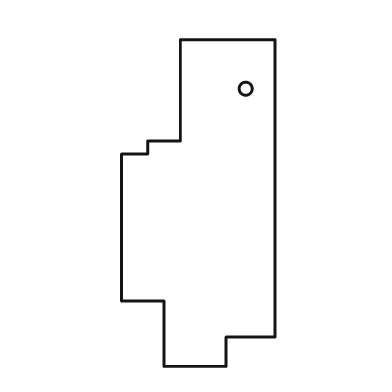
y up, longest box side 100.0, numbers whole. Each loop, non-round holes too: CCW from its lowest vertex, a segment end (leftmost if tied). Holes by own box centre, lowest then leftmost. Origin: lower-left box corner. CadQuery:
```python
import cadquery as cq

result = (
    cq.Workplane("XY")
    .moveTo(13.0, 0.0)
    .lineTo(32.0, 0.0)
    .lineTo(32.0, 9.0)
    .lineTo(47.0, 9.0)
    .lineTo(47.0, 100.0)
    .lineTo(18.0, 100.0)
    .lineTo(18.0, 69.0)
    .lineTo(8.0, 69.0)
    .lineTo(8.0, 65.0)
    .lineTo(0.0, 65.0)
    .lineTo(0.0, 20.0)
    .lineTo(13.0, 20.0)
    .close()
    .moveTo(38.0, 85.0)
    .circle(2.0)
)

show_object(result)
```